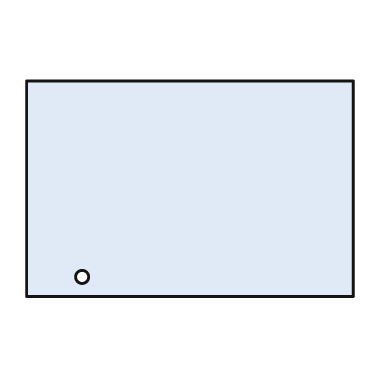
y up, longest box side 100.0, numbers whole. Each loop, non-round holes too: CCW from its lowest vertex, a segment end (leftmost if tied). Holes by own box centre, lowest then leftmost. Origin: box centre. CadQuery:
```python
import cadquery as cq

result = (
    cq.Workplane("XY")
    .moveTo(-50.0, -33.0)
    .lineTo(50.0, -33.0)
    .lineTo(50.0, 33.0)
    .lineTo(-50.0, 33.0)
    .close()
    .moveTo(-33.0, -27.0)
    .circle(2.0)
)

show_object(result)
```